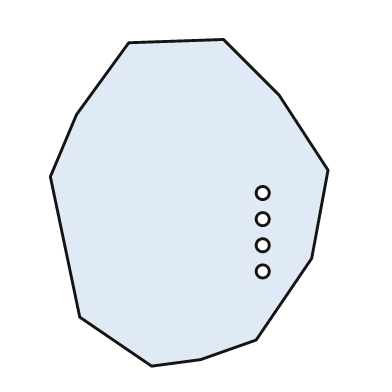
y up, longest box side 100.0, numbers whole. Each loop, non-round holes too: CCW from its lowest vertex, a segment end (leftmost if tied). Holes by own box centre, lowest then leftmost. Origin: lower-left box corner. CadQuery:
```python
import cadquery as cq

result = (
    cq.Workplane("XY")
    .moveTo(31.0, 0.0)
    .lineTo(46.0, 2.0)
    .lineTo(63.0, 8.0)
    .lineTo(80.0, 33.0)
    .lineTo(85.0, 60.0)
    .lineTo(70.0, 83.0)
    .lineTo(53.0, 100.0)
    .lineTo(24.0, 99.0)
    .lineTo(8.0, 77.0)
    .lineTo(0.0, 58.0)
    .lineTo(9.0, 15.0)
    .close()
    .moveTo(65.0, 29.0)
    .circle(2.0)
    .moveTo(65.0, 37.0)
    .circle(2.0)
    .moveTo(65.0, 45.0)
    .circle(2.0)
    .moveTo(65.0, 53.0)
    .circle(2.0)
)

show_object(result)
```